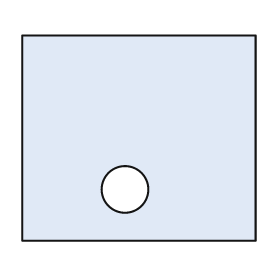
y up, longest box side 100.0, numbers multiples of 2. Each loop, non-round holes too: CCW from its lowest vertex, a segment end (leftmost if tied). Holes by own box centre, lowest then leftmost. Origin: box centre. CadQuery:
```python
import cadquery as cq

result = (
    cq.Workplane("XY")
    .moveTo(-50.0, -44.0)
    .lineTo(50.0, -44.0)
    .lineTo(50.0, 44.0)
    .lineTo(-50.0, 44.0)
    .close()
    .moveTo(-6.0, -22.0)
    .circle(10.0)
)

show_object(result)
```